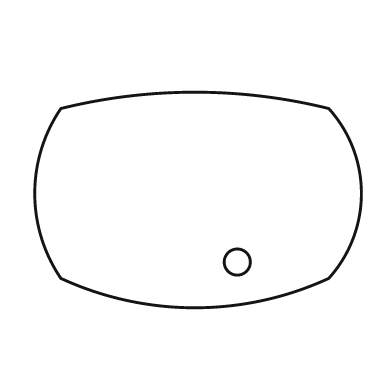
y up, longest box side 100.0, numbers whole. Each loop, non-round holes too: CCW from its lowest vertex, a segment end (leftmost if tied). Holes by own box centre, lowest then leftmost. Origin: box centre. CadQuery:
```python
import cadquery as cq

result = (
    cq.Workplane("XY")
    .moveTo(-42.0, -24.0)
    .threePointArc((-1.0, -33.0), (40.0, -24.0))
    .threePointArc((50.0, 2.0), (40.0, 28.0))
    .threePointArc((-1.0, 33.0), (-42.0, 28.0))
    .threePointArc((-50.0, 2.0), (-42.0, -24.0))
    .close()
    .moveTo(12.0, -19.0)
    .circle(4.0)
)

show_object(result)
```